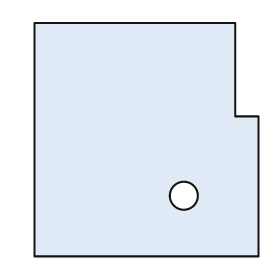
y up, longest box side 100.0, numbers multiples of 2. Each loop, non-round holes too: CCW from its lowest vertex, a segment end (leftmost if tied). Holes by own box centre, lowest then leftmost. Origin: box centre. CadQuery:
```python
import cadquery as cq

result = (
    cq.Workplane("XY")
    .moveTo(-48.0, -50.0)
    .lineTo(48.0, -50.0)
    .lineTo(48.0, 10.0)
    .lineTo(38.0, 10.0)
    .lineTo(38.0, 50.0)
    .lineTo(-48.0, 50.0)
    .close()
    .moveTo(16.0, -24.0)
    .circle(6.0)
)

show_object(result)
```